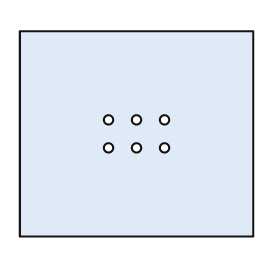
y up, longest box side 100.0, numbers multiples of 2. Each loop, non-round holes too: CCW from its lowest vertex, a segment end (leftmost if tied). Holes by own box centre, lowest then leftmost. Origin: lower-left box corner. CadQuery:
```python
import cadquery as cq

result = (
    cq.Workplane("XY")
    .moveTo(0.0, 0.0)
    .lineTo(100.0, 0.0)
    .lineTo(100.0, 88.0)
    .lineTo(0.0, 88.0)
    .close()
    .moveTo(38.0, 38.0)
    .circle(2.0)
    .moveTo(50.0, 38.0)
    .circle(2.0)
    .moveTo(62.0, 38.0)
    .circle(2.0)
    .moveTo(38.0, 50.0)
    .circle(2.0)
    .moveTo(50.0, 50.0)
    .circle(2.0)
    .moveTo(62.0, 50.0)
    .circle(2.0)
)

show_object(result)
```